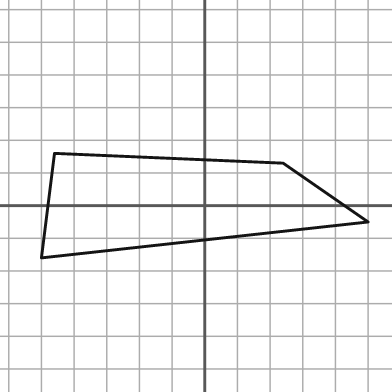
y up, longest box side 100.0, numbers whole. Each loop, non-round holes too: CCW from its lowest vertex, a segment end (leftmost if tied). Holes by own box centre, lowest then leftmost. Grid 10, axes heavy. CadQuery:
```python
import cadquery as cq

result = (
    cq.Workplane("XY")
    .moveTo(-50.0, -16.0)
    .lineTo(50.0, -5.0)
    .lineTo(24.0, 13.0)
    .lineTo(-46.0, 16.0)
    .close()
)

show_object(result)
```